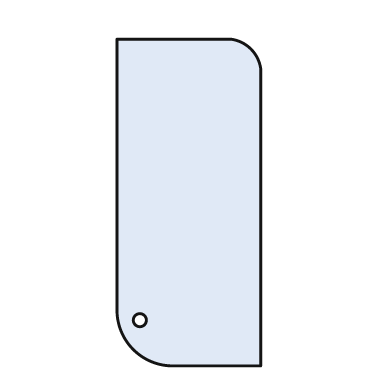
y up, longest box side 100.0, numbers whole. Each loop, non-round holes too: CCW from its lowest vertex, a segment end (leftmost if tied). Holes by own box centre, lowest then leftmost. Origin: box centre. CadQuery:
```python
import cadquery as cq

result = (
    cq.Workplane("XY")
    .moveTo(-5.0, -50.0)
    .lineTo(22.0, -50.0)
    .lineTo(22.0, 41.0)
    .threePointArc((19.0, 47.0), (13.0, 50.0))
    .lineTo(-22.0, 50.0)
    .lineTo(-22.0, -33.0)
    .threePointArc((-17.0, -45.0), (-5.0, -50.0))
    .close()
    .moveTo(-15.0, -36.0)
    .circle(2.0)
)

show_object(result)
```